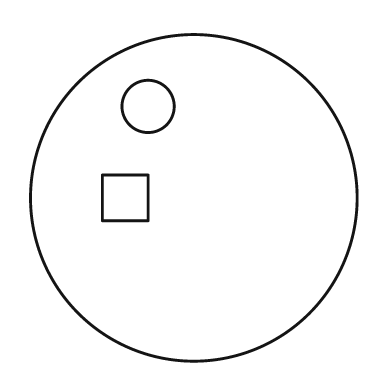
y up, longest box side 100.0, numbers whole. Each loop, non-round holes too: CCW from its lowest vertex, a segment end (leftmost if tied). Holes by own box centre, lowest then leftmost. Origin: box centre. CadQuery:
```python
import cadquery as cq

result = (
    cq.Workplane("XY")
    .moveTo(0.0, 0.0)
    .circle(50.0)
    .moveTo(-28.0, -7.0)
    .lineTo(-14.0, -7.0)
    .lineTo(-14.0, 7.0)
    .lineTo(-28.0, 7.0)
    .close()
    .moveTo(-14.0, 28.0)
    .circle(8.0)
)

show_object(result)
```